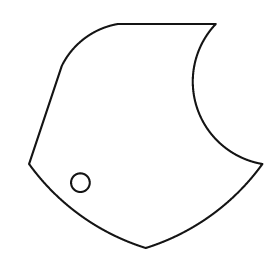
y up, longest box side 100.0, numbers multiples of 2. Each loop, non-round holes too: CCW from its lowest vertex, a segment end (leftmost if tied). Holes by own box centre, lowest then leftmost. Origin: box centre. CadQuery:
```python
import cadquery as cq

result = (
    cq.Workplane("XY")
    .moveTo(0.0, -48.0)
    .threePointArc((28.0, -34.0), (50.0, -12.0))
    .threePointArc((22.0, 12.0), (30.0, 48.0))
    .lineTo(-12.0, 48.0)
    .threePointArc((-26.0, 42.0), (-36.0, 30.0))
    .lineTo(-50.0, -12.0)
    .threePointArc((-28.0, -34.0), (0.0, -48.0))
    .close()
    .moveTo(-28.0, -20.0)
    .circle(4.0)
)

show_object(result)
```